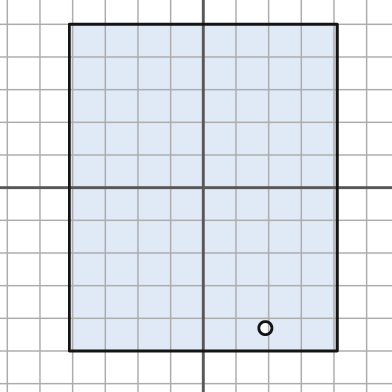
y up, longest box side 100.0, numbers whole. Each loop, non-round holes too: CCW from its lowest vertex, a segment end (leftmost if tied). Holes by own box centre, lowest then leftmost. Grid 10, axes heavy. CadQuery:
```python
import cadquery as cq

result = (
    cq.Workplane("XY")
    .moveTo(-41.0, -50.0)
    .lineTo(41.0, -50.0)
    .lineTo(41.0, 50.0)
    .lineTo(-41.0, 50.0)
    .close()
    .moveTo(19.0, -43.0)
    .circle(2.0)
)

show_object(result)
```